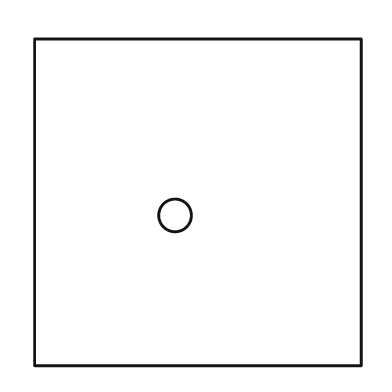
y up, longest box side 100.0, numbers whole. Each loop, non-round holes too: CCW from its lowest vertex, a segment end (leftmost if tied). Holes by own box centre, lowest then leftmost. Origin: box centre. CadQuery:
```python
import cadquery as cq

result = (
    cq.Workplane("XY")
    .moveTo(-50.0, -50.0)
    .lineTo(50.0, -50.0)
    .lineTo(50.0, 50.0)
    .lineTo(-50.0, 50.0)
    .close()
    .moveTo(-7.0, -4.0)
    .circle(5.0)
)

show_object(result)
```